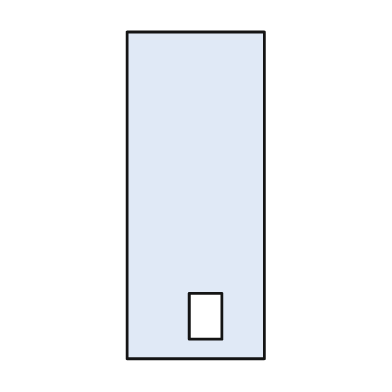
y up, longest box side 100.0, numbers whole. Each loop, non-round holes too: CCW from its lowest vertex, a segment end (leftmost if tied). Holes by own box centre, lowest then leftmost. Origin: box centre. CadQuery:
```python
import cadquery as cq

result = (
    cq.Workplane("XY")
    .moveTo(-21.0, -50.0)
    .lineTo(21.0, -50.0)
    .lineTo(21.0, 50.0)
    .lineTo(-21.0, 50.0)
    .close()
    .moveTo(-2.0, -44.0)
    .lineTo(8.0, -44.0)
    .lineTo(8.0, -30.0)
    .lineTo(-2.0, -30.0)
    .close()
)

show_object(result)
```